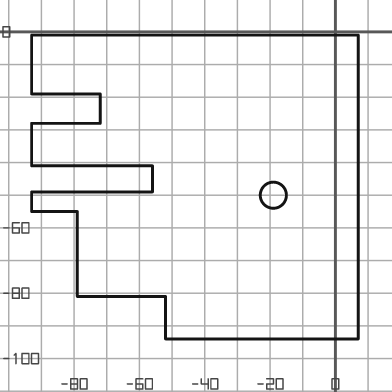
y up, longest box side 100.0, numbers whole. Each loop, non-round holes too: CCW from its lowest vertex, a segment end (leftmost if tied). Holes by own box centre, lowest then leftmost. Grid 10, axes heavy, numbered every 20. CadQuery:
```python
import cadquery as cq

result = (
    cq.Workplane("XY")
    .moveTo(-52.0, -94.0)
    .lineTo(7.0, -94.0)
    .lineTo(7.0, -1.0)
    .lineTo(-93.0, -1.0)
    .lineTo(-93.0, -19.0)
    .lineTo(-72.0, -19.0)
    .lineTo(-72.0, -28.0)
    .lineTo(-93.0, -28.0)
    .lineTo(-93.0, -41.0)
    .lineTo(-56.0, -41.0)
    .lineTo(-56.0, -49.0)
    .lineTo(-93.0, -49.0)
    .lineTo(-93.0, -55.0)
    .lineTo(-79.0, -55.0)
    .lineTo(-79.0, -81.0)
    .lineTo(-52.0, -81.0)
    .close()
    .moveTo(-19.0, -50.0)
    .circle(4.0)
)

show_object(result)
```